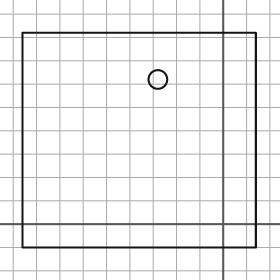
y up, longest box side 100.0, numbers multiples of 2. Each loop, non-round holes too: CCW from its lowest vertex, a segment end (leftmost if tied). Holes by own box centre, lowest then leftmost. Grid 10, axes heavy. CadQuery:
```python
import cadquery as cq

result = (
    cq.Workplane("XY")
    .moveTo(-86.0, -10.0)
    .lineTo(14.0, -10.0)
    .lineTo(14.0, 82.0)
    .lineTo(-86.0, 82.0)
    .close()
    .moveTo(-28.0, 62.0)
    .circle(4.0)
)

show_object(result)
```